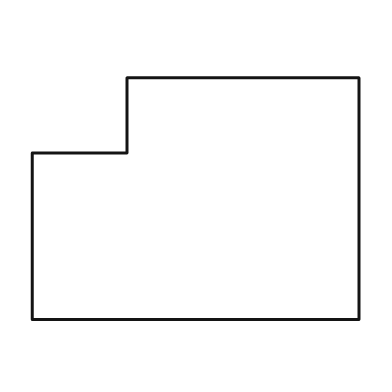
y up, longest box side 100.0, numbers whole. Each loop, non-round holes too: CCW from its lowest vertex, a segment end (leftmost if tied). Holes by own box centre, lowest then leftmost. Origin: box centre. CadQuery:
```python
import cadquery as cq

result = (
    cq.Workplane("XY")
    .moveTo(-50.0, -37.0)
    .lineTo(50.0, -37.0)
    .lineTo(50.0, 37.0)
    .lineTo(-21.0, 37.0)
    .lineTo(-21.0, 14.0)
    .lineTo(-50.0, 14.0)
    .close()
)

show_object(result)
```